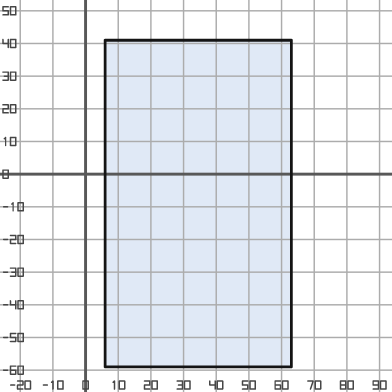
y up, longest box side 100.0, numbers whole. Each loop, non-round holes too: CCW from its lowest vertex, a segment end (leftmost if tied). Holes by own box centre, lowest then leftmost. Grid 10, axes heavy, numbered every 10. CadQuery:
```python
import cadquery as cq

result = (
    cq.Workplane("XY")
    .moveTo(6.0, -59.0)
    .lineTo(63.0, -59.0)
    .lineTo(63.0, 41.0)
    .lineTo(6.0, 41.0)
    .close()
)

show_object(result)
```